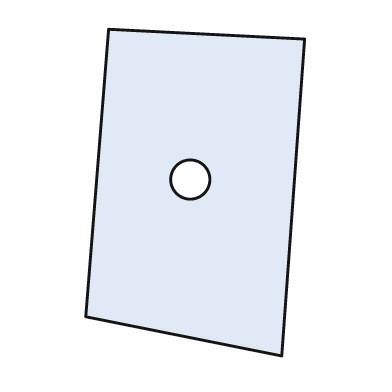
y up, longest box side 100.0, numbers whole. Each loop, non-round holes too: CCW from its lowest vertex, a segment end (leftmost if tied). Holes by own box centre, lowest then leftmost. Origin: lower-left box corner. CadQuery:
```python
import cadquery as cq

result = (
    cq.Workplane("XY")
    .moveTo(60.0, 0.0)
    .lineTo(67.0, 97.0)
    .lineTo(7.0, 100.0)
    .lineTo(0.0, 12.0)
    .close()
    .moveTo(32.0, 54.0)
    .circle(6.0)
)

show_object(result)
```